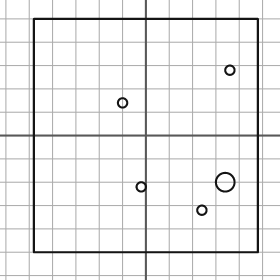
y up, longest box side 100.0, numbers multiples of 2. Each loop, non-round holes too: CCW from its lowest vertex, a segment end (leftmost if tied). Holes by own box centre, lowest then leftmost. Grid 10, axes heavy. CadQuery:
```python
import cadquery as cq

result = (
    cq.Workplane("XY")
    .moveTo(-48.0, -50.0)
    .lineTo(48.0, -50.0)
    .lineTo(48.0, 50.0)
    .lineTo(-48.0, 50.0)
    .close()
    .moveTo(24.0, -32.0)
    .circle(2.0)
    .moveTo(-2.0, -22.0)
    .circle(2.0)
    .moveTo(34.0, -20.0)
    .circle(4.0)
    .moveTo(-10.0, 14.0)
    .circle(2.0)
    .moveTo(36.0, 28.0)
    .circle(2.0)
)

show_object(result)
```